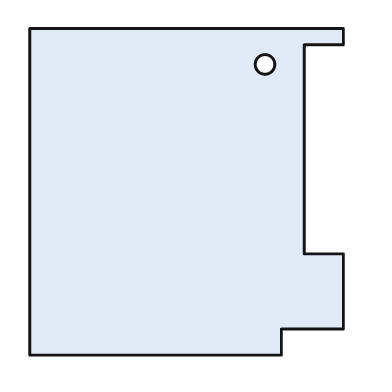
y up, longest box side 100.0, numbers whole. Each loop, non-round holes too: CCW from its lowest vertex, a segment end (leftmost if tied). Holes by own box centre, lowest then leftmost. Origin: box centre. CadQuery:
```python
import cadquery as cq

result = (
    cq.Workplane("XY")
    .moveTo(-48.0, -50.0)
    .lineTo(29.0, -50.0)
    .lineTo(29.0, -42.0)
    .lineTo(48.0, -42.0)
    .lineTo(48.0, -19.0)
    .lineTo(36.0, -19.0)
    .lineTo(36.0, 45.0)
    .lineTo(48.0, 45.0)
    .lineTo(48.0, 50.0)
    .lineTo(-48.0, 50.0)
    .close()
    .moveTo(24.0, 39.0)
    .circle(3.0)
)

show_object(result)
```